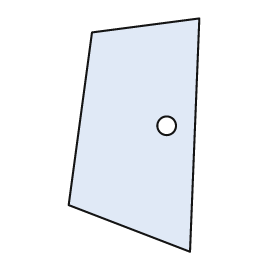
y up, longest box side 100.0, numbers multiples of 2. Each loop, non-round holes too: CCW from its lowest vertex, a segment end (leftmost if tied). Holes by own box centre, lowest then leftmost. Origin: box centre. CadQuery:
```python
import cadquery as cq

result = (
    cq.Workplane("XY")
    .moveTo(24.0, -50.0)
    .lineTo(28.0, 50.0)
    .lineTo(-18.0, 44.0)
    .lineTo(-28.0, -30.0)
    .close()
    .moveTo(14.0, 4.0)
    .circle(4.0)
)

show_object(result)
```